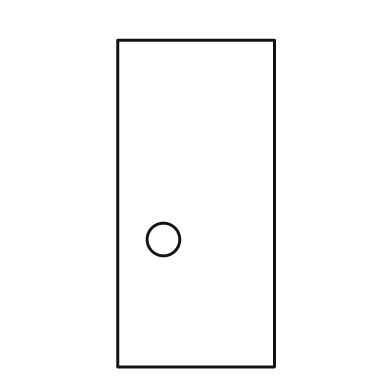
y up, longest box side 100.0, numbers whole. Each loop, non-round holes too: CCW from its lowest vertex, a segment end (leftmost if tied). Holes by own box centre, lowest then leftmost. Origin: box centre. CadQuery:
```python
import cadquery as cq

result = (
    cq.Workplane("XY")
    .moveTo(-24.0, -50.0)
    .lineTo(24.0, -50.0)
    .lineTo(24.0, 50.0)
    .lineTo(-24.0, 50.0)
    .close()
    .moveTo(-10.0, -11.0)
    .circle(5.0)
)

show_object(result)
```